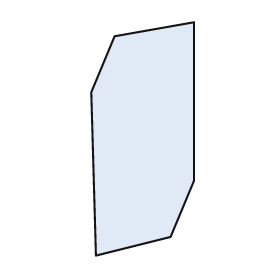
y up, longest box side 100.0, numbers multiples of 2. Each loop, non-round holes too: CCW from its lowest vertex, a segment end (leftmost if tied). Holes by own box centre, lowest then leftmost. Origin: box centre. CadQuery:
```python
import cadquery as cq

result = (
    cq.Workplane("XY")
    .moveTo(-20.0, -50.0)
    .lineTo(12.0, -42.0)
    .lineTo(22.0, -18.0)
    .lineTo(22.0, 50.0)
    .lineTo(-12.0, 44.0)
    .lineTo(-22.0, 20.0)
    .close()
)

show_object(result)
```